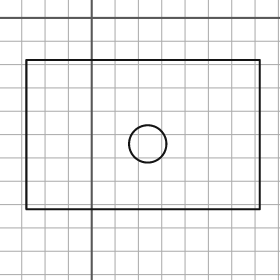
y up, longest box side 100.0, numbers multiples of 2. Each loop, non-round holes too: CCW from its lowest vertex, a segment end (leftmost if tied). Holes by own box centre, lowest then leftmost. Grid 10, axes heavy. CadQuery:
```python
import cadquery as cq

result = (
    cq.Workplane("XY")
    .moveTo(-28.0, -82.0)
    .lineTo(72.0, -82.0)
    .lineTo(72.0, -18.0)
    .lineTo(-28.0, -18.0)
    .close()
    .moveTo(24.0, -54.0)
    .circle(8.0)
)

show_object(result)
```